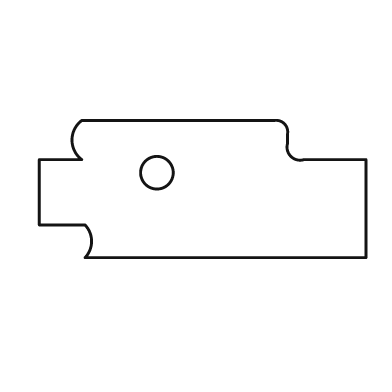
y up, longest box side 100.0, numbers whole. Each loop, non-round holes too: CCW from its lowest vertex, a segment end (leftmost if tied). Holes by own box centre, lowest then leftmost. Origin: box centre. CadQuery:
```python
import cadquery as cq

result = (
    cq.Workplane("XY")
    .moveTo(-36.0, -21.0)
    .lineTo(50.0, -21.0)
    .lineTo(50.0, 9.0)
    .lineTo(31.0, 9.0)
    .threePointArc((27.0, 10.0), (26.0, 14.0))
    .lineTo(26.0, 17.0)
    .threePointArc((25.0, 20.0), (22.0, 21.0))
    .lineTo(-37.0, 21.0)
    .threePointArc((-40.0, 15.0), (-37.0, 9.0))
    .lineTo(-50.0, 9.0)
    .lineTo(-50.0, -11.0)
    .lineTo(-36.0, -11.0)
    .threePointArc((-34.0, -16.0), (-36.0, -21.0))
    .close()
    .moveTo(-14.0, 5.0)
    .circle(5.0)
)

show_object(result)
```